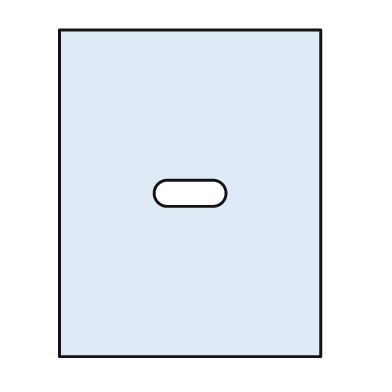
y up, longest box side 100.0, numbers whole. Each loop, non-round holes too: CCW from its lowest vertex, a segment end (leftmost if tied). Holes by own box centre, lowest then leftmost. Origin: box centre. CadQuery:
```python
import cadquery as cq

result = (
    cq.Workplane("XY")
    .moveTo(-40.0, -50.0)
    .lineTo(40.0, -50.0)
    .lineTo(40.0, 50.0)
    .lineTo(-40.0, 50.0)
    .close()
    .moveTo(-7.0, -4.0)
    .lineTo(7.0, -4.0)
    .threePointArc((11.0, 0.0), (7.0, 4.0))
    .lineTo(-7.0, 4.0)
    .threePointArc((-11.0, 0.0), (-7.0, -4.0))
    .close()
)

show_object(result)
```